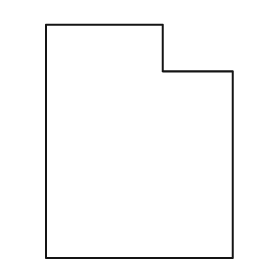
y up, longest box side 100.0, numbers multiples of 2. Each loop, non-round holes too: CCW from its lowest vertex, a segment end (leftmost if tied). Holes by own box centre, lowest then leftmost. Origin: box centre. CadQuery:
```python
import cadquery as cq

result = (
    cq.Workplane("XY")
    .moveTo(-40.0, -50.0)
    .lineTo(40.0, -50.0)
    .lineTo(40.0, 30.0)
    .lineTo(10.0, 30.0)
    .lineTo(10.0, 50.0)
    .lineTo(-40.0, 50.0)
    .close()
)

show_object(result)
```